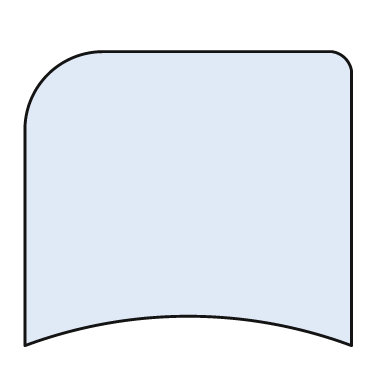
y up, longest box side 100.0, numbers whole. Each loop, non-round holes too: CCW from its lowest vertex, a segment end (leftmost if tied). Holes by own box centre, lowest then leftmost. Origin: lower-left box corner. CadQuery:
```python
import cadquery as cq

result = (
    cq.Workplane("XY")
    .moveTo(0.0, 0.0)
    .threePointArc((50.0, 9.0), (100.0, 0.0))
    .lineTo(100.0, 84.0)
    .threePointArc((98.0, 88.0), (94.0, 90.0))
    .lineTo(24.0, 90.0)
    .threePointArc((7.0, 83.0), (0.0, 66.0))
    .close()
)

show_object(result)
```